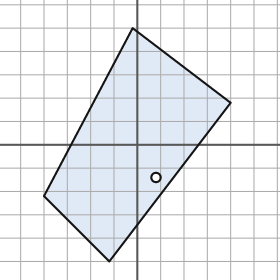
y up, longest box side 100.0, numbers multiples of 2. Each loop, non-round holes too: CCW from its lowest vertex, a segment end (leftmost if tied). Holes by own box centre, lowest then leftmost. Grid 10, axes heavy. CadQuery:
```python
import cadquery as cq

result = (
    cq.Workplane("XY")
    .moveTo(-12.0, -50.0)
    .lineTo(40.0, 18.0)
    .lineTo(-2.0, 50.0)
    .lineTo(-40.0, -22.0)
    .close()
    .moveTo(8.0, -14.0)
    .circle(2.0)
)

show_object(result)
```